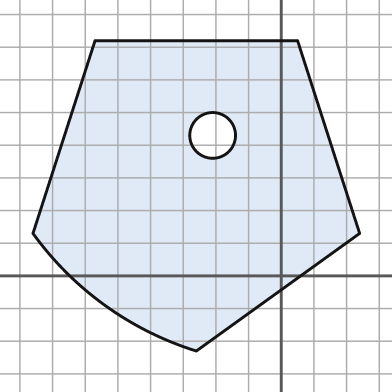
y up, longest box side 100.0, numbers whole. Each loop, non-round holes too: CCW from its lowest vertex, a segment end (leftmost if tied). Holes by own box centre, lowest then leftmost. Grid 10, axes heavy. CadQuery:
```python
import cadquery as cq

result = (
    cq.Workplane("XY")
    .moveTo(-26.0, -23.0)
    .lineTo(24.0, 13.0)
    .lineTo(5.0, 72.0)
    .lineTo(-57.0, 72.0)
    .lineTo(-76.0, 13.0)
    .threePointArc((-54.0, -9.0), (-26.0, -23.0))
    .close()
    .moveTo(-21.0, 43.0)
    .circle(7.0)
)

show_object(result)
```